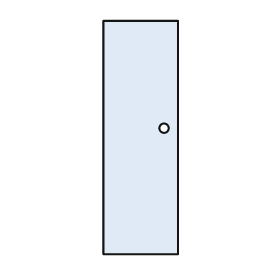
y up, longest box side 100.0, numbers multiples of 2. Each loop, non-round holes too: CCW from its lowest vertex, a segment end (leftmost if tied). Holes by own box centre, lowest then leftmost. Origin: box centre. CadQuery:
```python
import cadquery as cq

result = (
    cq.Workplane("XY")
    .moveTo(-16.0, -50.0)
    .lineTo(16.0, -50.0)
    .lineTo(16.0, 50.0)
    .lineTo(-16.0, 50.0)
    .close()
    .moveTo(10.0, 4.0)
    .circle(2.0)
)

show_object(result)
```